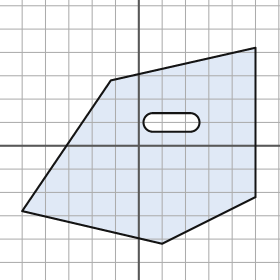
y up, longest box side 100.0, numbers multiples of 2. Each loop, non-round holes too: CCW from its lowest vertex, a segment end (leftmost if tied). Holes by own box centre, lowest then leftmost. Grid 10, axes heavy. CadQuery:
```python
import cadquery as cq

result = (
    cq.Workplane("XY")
    .moveTo(10.0, -42.0)
    .lineTo(50.0, -22.0)
    .lineTo(50.0, 42.0)
    .lineTo(-12.0, 28.0)
    .lineTo(-50.0, -28.0)
    .close()
    .moveTo(6.0, 6.0)
    .lineTo(22.0, 6.0)
    .threePointArc((26.0, 10.0), (22.0, 14.0))
    .lineTo(6.0, 14.0)
    .threePointArc((2.0, 10.0), (6.0, 6.0))
    .close()
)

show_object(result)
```